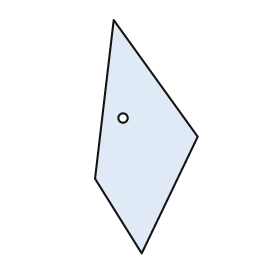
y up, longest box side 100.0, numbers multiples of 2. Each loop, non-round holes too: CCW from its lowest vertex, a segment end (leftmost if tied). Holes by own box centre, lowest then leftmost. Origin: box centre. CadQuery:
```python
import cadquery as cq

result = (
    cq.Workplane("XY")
    .moveTo(-2.0, -50.0)
    .lineTo(22.0, 0.0)
    .lineTo(-14.0, 50.0)
    .lineTo(-22.0, -18.0)
    .close()
    .moveTo(-10.0, 8.0)
    .circle(2.0)
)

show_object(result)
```